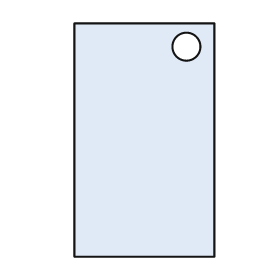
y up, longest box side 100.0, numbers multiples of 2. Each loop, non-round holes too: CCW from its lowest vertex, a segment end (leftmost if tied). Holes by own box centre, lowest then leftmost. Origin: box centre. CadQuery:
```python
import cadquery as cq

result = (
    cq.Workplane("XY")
    .moveTo(-30.0, -50.0)
    .lineTo(30.0, -50.0)
    .lineTo(30.0, 50.0)
    .lineTo(-30.0, 50.0)
    .close()
    .moveTo(18.0, 40.0)
    .circle(6.0)
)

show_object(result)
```